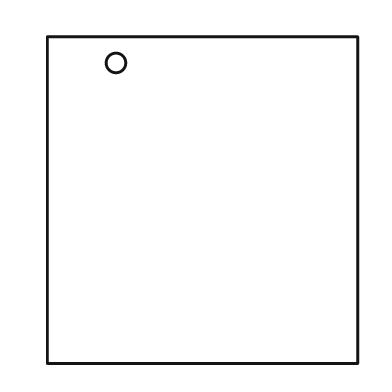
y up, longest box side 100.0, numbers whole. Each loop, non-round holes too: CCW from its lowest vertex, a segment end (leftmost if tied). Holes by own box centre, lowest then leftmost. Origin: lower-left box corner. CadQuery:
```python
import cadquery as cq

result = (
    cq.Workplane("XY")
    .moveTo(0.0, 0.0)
    .lineTo(95.0, 0.0)
    .lineTo(95.0, 100.0)
    .lineTo(0.0, 100.0)
    .close()
    .moveTo(21.0, 92.0)
    .circle(3.0)
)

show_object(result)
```